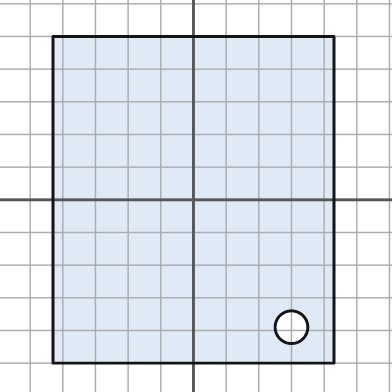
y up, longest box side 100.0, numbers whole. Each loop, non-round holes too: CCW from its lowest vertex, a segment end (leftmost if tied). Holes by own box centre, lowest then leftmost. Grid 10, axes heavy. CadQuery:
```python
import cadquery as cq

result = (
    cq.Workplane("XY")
    .moveTo(-43.0, -50.0)
    .lineTo(43.0, -50.0)
    .lineTo(43.0, 50.0)
    .lineTo(-43.0, 50.0)
    .close()
    .moveTo(30.0, -39.0)
    .circle(5.0)
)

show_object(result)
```